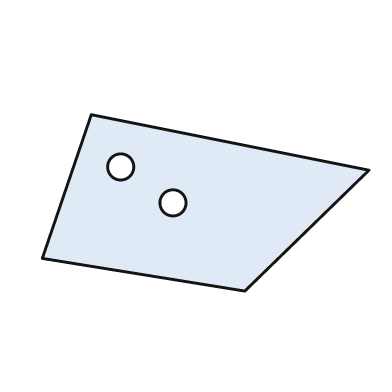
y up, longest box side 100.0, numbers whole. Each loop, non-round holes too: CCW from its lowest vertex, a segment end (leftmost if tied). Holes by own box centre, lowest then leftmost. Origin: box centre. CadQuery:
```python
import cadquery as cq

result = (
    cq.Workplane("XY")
    .moveTo(12.0, -27.0)
    .lineTo(50.0, 10.0)
    .lineTo(-35.0, 27.0)
    .lineTo(-50.0, -17.0)
    .close()
    .moveTo(-10.0, 0.0)
    .circle(4.0)
    .moveTo(-26.0, 11.0)
    .circle(4.0)
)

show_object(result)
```